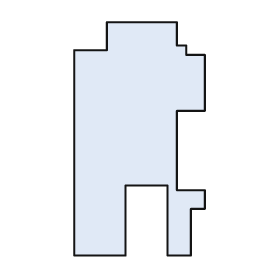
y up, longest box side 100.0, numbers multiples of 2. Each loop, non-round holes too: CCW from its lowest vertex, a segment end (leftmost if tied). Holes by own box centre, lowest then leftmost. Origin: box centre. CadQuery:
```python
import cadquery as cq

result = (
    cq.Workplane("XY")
    .moveTo(-28.0, -50.0)
    .lineTo(-6.0, -50.0)
    .lineTo(-6.0, -20.0)
    .lineTo(12.0, -20.0)
    .lineTo(12.0, -50.0)
    .lineTo(22.0, -50.0)
    .lineTo(22.0, -30.0)
    .lineTo(28.0, -30.0)
    .lineTo(28.0, -22.0)
    .lineTo(16.0, -22.0)
    .lineTo(16.0, 12.0)
    .lineTo(28.0, 12.0)
    .lineTo(28.0, 36.0)
    .lineTo(20.0, 36.0)
    .lineTo(20.0, 40.0)
    .lineTo(16.0, 40.0)
    .lineTo(16.0, 50.0)
    .lineTo(-14.0, 50.0)
    .lineTo(-14.0, 38.0)
    .lineTo(-28.0, 38.0)
    .close()
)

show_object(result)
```